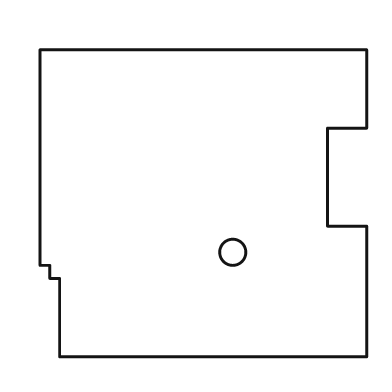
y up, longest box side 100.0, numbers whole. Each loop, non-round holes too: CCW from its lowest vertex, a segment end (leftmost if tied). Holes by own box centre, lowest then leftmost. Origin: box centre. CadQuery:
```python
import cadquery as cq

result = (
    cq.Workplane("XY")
    .moveTo(-44.0, -47.0)
    .lineTo(50.0, -47.0)
    .lineTo(50.0, -7.0)
    .lineTo(38.0, -7.0)
    .lineTo(38.0, 23.0)
    .lineTo(50.0, 23.0)
    .lineTo(50.0, 47.0)
    .lineTo(-50.0, 47.0)
    .lineTo(-50.0, -19.0)
    .lineTo(-47.0, -19.0)
    .lineTo(-47.0, -23.0)
    .lineTo(-44.0, -23.0)
    .close()
    .moveTo(9.0, -15.0)
    .circle(4.0)
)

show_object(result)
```